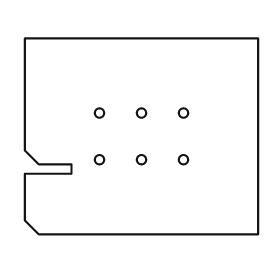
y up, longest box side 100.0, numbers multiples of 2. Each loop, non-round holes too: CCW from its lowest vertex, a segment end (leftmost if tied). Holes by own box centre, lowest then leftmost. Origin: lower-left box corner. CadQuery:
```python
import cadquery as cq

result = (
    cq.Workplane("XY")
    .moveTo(6.0, 0.0)
    .lineTo(100.0, 0.0)
    .lineTo(100.0, 84.0)
    .lineTo(0.0, 84.0)
    .lineTo(0.0, 36.0)
    .lineTo(6.0, 30.0)
    .lineTo(20.0, 30.0)
    .lineTo(20.0, 26.0)
    .lineTo(0.0, 26.0)
    .lineTo(0.0, 6.0)
    .close()
    .moveTo(32.0, 32.0)
    .circle(2.0)
    .moveTo(50.0, 32.0)
    .circle(2.0)
    .moveTo(68.0, 32.0)
    .circle(2.0)
    .moveTo(32.0, 52.0)
    .circle(2.0)
    .moveTo(50.0, 52.0)
    .circle(2.0)
    .moveTo(68.0, 52.0)
    .circle(2.0)
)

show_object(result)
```